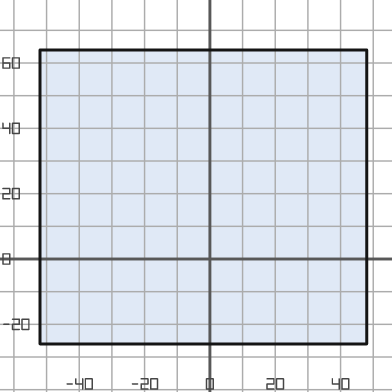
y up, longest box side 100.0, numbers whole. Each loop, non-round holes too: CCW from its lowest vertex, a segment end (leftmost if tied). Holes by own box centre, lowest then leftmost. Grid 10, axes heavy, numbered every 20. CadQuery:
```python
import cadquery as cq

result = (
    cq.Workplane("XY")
    .moveTo(-52.0, -26.0)
    .lineTo(48.0, -26.0)
    .lineTo(48.0, 64.0)
    .lineTo(-52.0, 64.0)
    .close()
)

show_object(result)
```